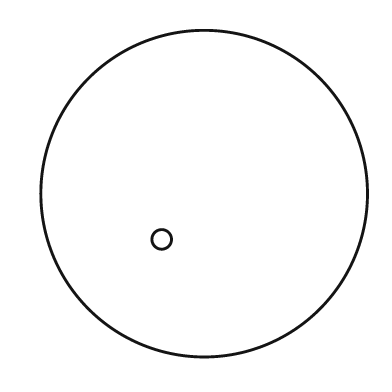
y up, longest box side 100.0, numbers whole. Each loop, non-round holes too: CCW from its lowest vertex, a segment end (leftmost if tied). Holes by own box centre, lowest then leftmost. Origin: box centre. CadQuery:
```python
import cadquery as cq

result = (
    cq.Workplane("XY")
    .moveTo(0.0, 0.0)
    .circle(50.0)
    .moveTo(-13.0, -14.0)
    .circle(3.0)
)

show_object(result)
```